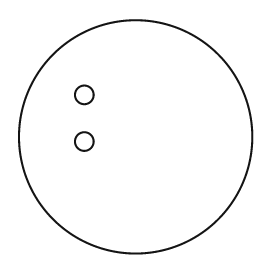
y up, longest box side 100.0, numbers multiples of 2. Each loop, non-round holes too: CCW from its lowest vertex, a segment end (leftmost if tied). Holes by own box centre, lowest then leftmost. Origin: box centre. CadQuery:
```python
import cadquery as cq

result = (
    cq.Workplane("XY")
    .moveTo(0.0, 0.0)
    .circle(50.0)
    .moveTo(-22.0, -2.0)
    .circle(4.0)
    .moveTo(-22.0, 18.0)
    .circle(4.0)
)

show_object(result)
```